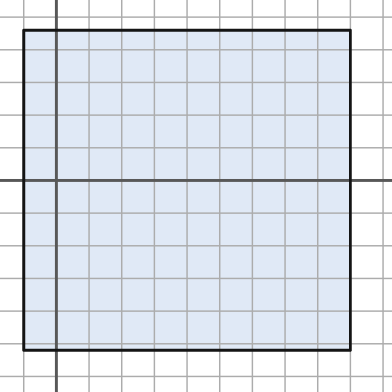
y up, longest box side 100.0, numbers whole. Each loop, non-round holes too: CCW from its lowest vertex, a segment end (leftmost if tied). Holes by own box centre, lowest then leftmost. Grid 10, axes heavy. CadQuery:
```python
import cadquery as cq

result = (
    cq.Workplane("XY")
    .moveTo(-10.0, -52.0)
    .lineTo(90.0, -52.0)
    .lineTo(90.0, 46.0)
    .lineTo(-10.0, 46.0)
    .close()
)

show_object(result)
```